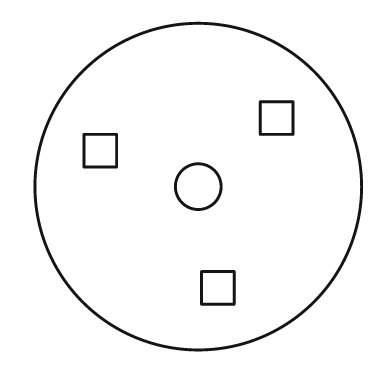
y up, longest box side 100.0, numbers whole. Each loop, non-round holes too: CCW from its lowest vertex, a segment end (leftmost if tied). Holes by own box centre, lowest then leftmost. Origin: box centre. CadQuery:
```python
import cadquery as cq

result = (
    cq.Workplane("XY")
    .moveTo(0.0, 0.0)
    .circle(50.0)
    .moveTo(1.0, -36.0)
    .lineTo(11.0, -36.0)
    .lineTo(11.0, -26.0)
    .lineTo(1.0, -26.0)
    .close()
    .moveTo(0.0, 0.0)
    .circle(7.0)
    .moveTo(-35.0, 6.0)
    .lineTo(-25.0, 6.0)
    .lineTo(-25.0, 16.0)
    .lineTo(-35.0, 16.0)
    .close()
    .moveTo(19.0, 16.0)
    .lineTo(29.0, 16.0)
    .lineTo(29.0, 26.0)
    .lineTo(19.0, 26.0)
    .close()
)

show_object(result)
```